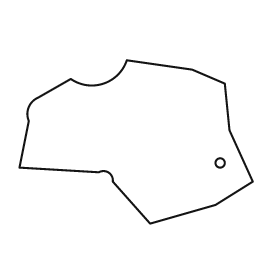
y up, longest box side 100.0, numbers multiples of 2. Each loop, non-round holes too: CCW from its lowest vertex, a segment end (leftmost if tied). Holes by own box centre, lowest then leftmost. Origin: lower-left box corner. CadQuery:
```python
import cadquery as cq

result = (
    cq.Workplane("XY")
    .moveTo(56.0, 0.0)
    .lineTo(84.0, 8.0)
    .lineTo(100.0, 18.0)
    .lineTo(90.0, 40.0)
    .lineTo(88.0, 60.0)
    .lineTo(74.0, 66.0)
    .lineTo(46.0, 70.0)
    .threePointArc((36.0, 60.0), (22.0, 62.0))
    .lineTo(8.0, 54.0)
    .threePointArc((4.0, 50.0), (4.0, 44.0))
    .lineTo(0.0, 24.0)
    .lineTo(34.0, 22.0)
    .threePointArc((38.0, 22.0), (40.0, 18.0))
    .close()
    .moveTo(86.0, 26.0)
    .circle(2.0)
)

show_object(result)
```